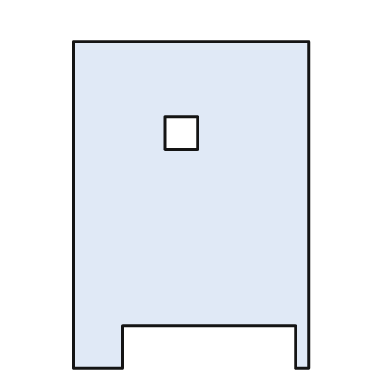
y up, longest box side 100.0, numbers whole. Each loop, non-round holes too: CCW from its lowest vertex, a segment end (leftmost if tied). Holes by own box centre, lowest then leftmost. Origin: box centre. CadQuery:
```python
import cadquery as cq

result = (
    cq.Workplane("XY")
    .moveTo(-36.0, -50.0)
    .lineTo(-21.0, -50.0)
    .lineTo(-21.0, -37.0)
    .lineTo(32.0, -37.0)
    .lineTo(32.0, -50.0)
    .lineTo(36.0, -50.0)
    .lineTo(36.0, 50.0)
    .lineTo(-36.0, 50.0)
    .close()
    .moveTo(-8.0, 17.0)
    .lineTo(2.0, 17.0)
    .lineTo(2.0, 27.0)
    .lineTo(-8.0, 27.0)
    .close()
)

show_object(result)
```